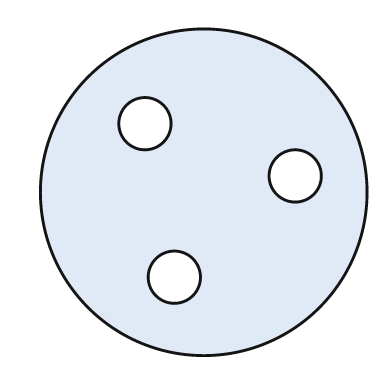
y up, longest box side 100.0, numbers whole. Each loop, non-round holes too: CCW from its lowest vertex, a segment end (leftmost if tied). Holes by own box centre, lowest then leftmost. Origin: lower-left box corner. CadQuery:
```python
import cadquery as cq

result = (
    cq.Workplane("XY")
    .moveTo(50.0, 50.0)
    .circle(50.0)
    .moveTo(41.0, 24.0)
    .circle(8.0)
    .moveTo(78.0, 55.0)
    .circle(8.0)
    .moveTo(32.0, 71.0)
    .circle(8.0)
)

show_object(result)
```